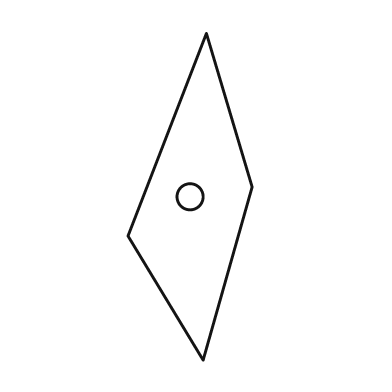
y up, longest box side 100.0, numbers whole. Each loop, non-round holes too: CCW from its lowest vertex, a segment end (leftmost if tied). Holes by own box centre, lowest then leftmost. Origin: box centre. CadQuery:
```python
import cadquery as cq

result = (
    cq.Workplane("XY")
    .moveTo(4.0, -50.0)
    .lineTo(19.0, 3.0)
    .lineTo(5.0, 50.0)
    .lineTo(-19.0, -12.0)
    .close()
    .moveTo(0.0, 0.0)
    .circle(4.0)
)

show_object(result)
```